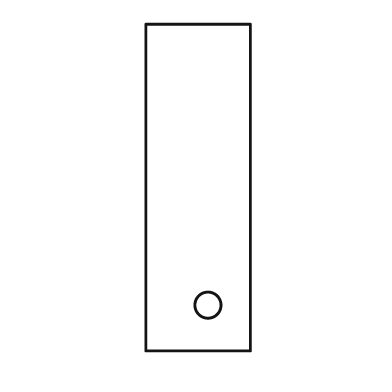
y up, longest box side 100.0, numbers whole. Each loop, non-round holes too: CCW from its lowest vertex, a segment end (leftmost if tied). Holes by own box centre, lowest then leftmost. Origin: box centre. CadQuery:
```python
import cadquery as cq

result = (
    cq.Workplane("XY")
    .moveTo(-16.0, -50.0)
    .lineTo(16.0, -50.0)
    .lineTo(16.0, 50.0)
    .lineTo(-16.0, 50.0)
    .close()
    .moveTo(3.0, -36.0)
    .circle(4.0)
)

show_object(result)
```